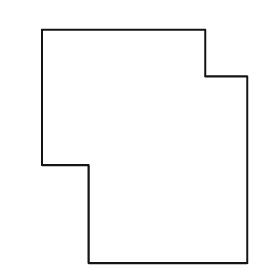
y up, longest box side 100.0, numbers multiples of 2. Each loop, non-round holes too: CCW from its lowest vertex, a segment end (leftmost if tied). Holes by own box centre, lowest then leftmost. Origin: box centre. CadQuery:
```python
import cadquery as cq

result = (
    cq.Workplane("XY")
    .moveTo(-24.0, -50.0)
    .lineTo(44.0, -50.0)
    .lineTo(44.0, 30.0)
    .lineTo(26.0, 30.0)
    .lineTo(26.0, 50.0)
    .lineTo(-44.0, 50.0)
    .lineTo(-44.0, -8.0)
    .lineTo(-24.0, -8.0)
    .close()
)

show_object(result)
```